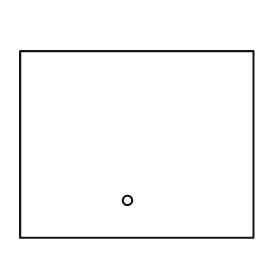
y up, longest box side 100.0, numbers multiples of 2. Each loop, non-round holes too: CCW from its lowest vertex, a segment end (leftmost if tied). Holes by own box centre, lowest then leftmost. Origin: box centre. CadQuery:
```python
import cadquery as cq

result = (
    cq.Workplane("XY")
    .moveTo(-50.0, -40.0)
    .lineTo(50.0, -40.0)
    .lineTo(50.0, 40.0)
    .lineTo(-50.0, 40.0)
    .close()
    .moveTo(-4.0, -24.0)
    .circle(2.0)
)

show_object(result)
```